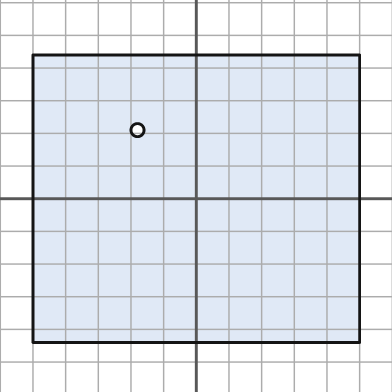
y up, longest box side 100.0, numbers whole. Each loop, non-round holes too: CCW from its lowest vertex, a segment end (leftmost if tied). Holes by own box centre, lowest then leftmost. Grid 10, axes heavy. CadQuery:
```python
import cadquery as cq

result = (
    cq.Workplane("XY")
    .moveTo(-50.0, -44.0)
    .lineTo(50.0, -44.0)
    .lineTo(50.0, 44.0)
    .lineTo(-50.0, 44.0)
    .close()
    .moveTo(-18.0, 21.0)
    .circle(2.0)
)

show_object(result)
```